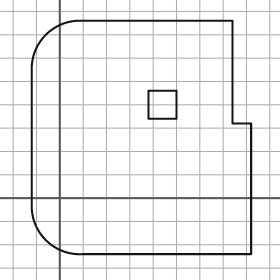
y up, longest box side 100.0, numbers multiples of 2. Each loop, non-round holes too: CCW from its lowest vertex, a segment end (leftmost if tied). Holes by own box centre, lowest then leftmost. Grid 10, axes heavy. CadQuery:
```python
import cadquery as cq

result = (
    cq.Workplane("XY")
    .moveTo(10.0, -24.0)
    .lineTo(82.0, -24.0)
    .lineTo(82.0, 32.0)
    .lineTo(74.0, 32.0)
    .lineTo(74.0, 76.0)
    .lineTo(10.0, 76.0)
    .threePointArc((-6.0, 70.0), (-12.0, 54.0))
    .lineTo(-12.0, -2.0)
    .threePointArc((-6.0, -18.0), (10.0, -24.0))
    .close()
    .moveTo(38.0, 34.0)
    .lineTo(50.0, 34.0)
    .lineTo(50.0, 46.0)
    .lineTo(38.0, 46.0)
    .close()
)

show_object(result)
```